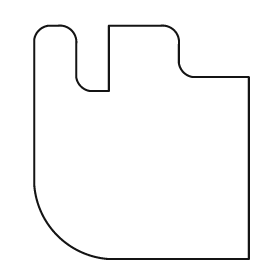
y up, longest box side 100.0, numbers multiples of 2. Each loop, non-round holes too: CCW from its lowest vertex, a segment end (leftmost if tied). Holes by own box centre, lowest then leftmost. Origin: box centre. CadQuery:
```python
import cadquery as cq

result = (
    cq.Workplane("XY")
    .moveTo(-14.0, -50.0)
    .lineTo(46.0, -50.0)
    .lineTo(46.0, 28.0)
    .lineTo(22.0, 28.0)
    .threePointArc((18.0, 30.0), (16.0, 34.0))
    .lineTo(16.0, 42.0)
    .threePointArc((14.0, 48.0), (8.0, 50.0))
    .lineTo(-14.0, 50.0)
    .lineTo(-14.0, 22.0)
    .lineTo(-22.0, 22.0)
    .threePointArc((-26.0, 24.0), (-28.0, 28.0))
    .lineTo(-28.0, 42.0)
    .threePointArc((-30.0, 48.0), (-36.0, 50.0))
    .lineTo(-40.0, 50.0)
    .threePointArc((-44.0, 48.0), (-46.0, 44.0))
    .lineTo(-46.0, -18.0)
    .threePointArc((-36.0, -40.0), (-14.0, -50.0))
    .close()
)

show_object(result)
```